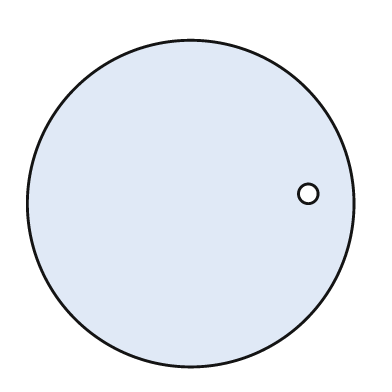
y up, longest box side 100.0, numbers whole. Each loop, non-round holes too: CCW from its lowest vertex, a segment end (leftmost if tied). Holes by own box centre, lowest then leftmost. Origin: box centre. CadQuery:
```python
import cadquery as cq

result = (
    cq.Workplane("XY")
    .moveTo(0.0, 0.0)
    .circle(50.0)
    .moveTo(36.0, 3.0)
    .circle(3.0)
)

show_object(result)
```